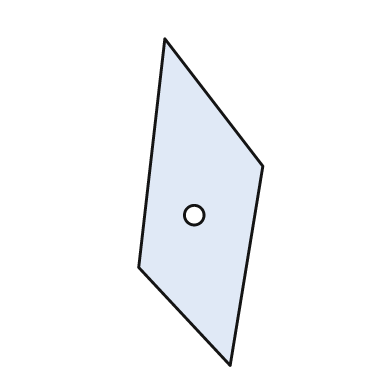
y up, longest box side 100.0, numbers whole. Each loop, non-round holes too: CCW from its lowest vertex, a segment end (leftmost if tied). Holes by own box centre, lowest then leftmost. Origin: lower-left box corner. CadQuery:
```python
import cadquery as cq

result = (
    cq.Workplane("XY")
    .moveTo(28.0, 0.0)
    .lineTo(38.0, 61.0)
    .lineTo(8.0, 100.0)
    .lineTo(0.0, 30.0)
    .close()
    .moveTo(17.0, 46.0)
    .circle(3.0)
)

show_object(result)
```